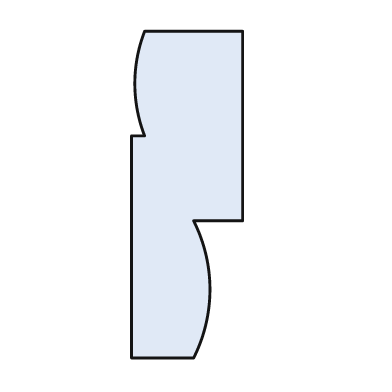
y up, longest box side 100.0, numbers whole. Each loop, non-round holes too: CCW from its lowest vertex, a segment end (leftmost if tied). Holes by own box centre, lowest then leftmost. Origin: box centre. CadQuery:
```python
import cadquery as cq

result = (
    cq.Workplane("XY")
    .moveTo(-17.0, -50.0)
    .lineTo(2.0, -50.0)
    .threePointArc((7.0, -29.0), (2.0, -8.0))
    .lineTo(17.0, -8.0)
    .lineTo(17.0, 50.0)
    .lineTo(-13.0, 50.0)
    .threePointArc((-16.0, 34.0), (-13.0, 18.0))
    .lineTo(-17.0, 18.0)
    .close()
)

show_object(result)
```